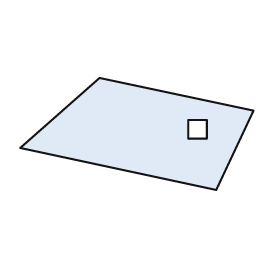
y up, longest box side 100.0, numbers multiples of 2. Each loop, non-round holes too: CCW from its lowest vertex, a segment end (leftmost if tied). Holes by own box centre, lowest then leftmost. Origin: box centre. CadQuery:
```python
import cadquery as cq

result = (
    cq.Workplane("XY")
    .moveTo(34.0, -24.0)
    .lineTo(50.0, 10.0)
    .lineTo(-16.0, 24.0)
    .lineTo(-50.0, -6.0)
    .close()
    .moveTo(22.0, -2.0)
    .lineTo(30.0, -2.0)
    .lineTo(30.0, 6.0)
    .lineTo(22.0, 6.0)
    .close()
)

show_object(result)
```